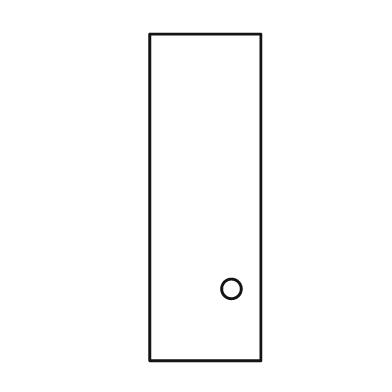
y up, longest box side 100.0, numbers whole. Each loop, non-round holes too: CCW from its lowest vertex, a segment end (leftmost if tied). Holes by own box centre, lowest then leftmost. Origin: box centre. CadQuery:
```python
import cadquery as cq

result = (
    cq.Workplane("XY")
    .moveTo(-17.0, -50.0)
    .lineTo(17.0, -50.0)
    .lineTo(17.0, 50.0)
    .lineTo(-17.0, 50.0)
    .close()
    .moveTo(8.0, -28.0)
    .circle(3.0)
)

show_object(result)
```